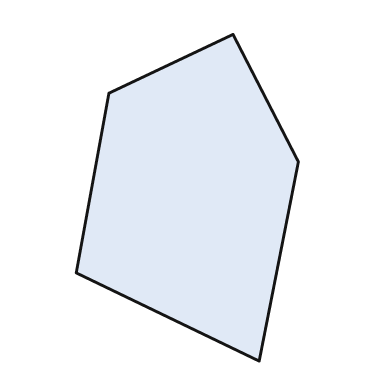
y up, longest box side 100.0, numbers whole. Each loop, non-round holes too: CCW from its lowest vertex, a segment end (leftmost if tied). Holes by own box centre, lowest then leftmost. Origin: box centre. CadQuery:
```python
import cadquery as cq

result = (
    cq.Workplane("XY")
    .moveTo(22.0, -50.0)
    .lineTo(34.0, 11.0)
    .lineTo(14.0, 50.0)
    .lineTo(-24.0, 32.0)
    .lineTo(-34.0, -23.0)
    .close()
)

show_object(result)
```